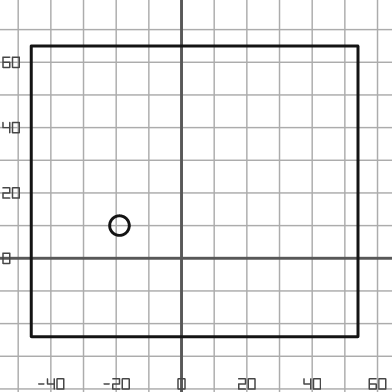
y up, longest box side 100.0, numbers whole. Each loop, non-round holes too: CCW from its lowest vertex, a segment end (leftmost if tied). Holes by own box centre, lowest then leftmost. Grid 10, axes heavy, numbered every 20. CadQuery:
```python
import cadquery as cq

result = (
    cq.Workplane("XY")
    .moveTo(-46.0, -24.0)
    .lineTo(54.0, -24.0)
    .lineTo(54.0, 65.0)
    .lineTo(-46.0, 65.0)
    .close()
    .moveTo(-19.0, 10.0)
    .circle(3.0)
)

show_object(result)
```